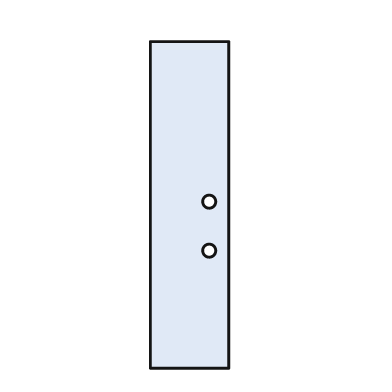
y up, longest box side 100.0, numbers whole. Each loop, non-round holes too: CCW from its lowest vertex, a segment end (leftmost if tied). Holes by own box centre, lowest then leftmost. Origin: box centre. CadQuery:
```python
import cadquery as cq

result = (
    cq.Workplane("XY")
    .moveTo(-12.0, -50.0)
    .lineTo(12.0, -50.0)
    .lineTo(12.0, 50.0)
    .lineTo(-12.0, 50.0)
    .close()
    .moveTo(6.0, -14.0)
    .circle(2.0)
    .moveTo(6.0, 1.0)
    .circle(2.0)
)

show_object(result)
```